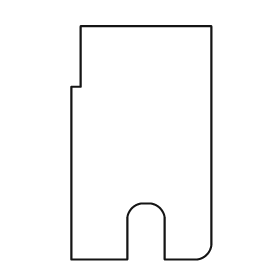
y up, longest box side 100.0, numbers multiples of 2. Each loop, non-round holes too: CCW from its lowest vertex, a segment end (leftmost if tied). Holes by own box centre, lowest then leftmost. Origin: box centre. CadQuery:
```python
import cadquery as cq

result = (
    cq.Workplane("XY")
    .moveTo(-30.0, -50.0)
    .lineTo(-6.0, -50.0)
    .lineTo(-6.0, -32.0)
    .threePointArc((-4.0, -28.0), (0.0, -26.0))
    .lineTo(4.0, -26.0)
    .threePointArc((8.0, -28.0), (10.0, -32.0))
    .lineTo(10.0, -50.0)
    .lineTo(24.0, -50.0)
    .threePointArc((28.0, -48.0), (30.0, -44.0))
    .lineTo(30.0, 50.0)
    .lineTo(-26.0, 50.0)
    .lineTo(-26.0, 24.0)
    .lineTo(-30.0, 24.0)
    .close()
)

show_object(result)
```